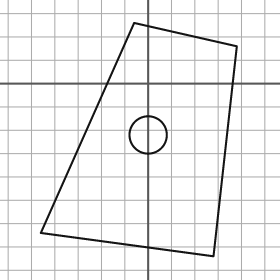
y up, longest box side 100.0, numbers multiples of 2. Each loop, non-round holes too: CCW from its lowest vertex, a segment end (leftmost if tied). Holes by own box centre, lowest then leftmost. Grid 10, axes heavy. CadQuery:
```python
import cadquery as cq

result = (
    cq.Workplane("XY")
    .moveTo(28.0, -74.0)
    .lineTo(38.0, 16.0)
    .lineTo(-6.0, 26.0)
    .lineTo(-46.0, -64.0)
    .close()
    .moveTo(0.0, -22.0)
    .circle(8.0)
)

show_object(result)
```